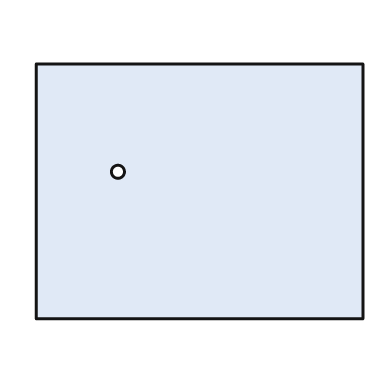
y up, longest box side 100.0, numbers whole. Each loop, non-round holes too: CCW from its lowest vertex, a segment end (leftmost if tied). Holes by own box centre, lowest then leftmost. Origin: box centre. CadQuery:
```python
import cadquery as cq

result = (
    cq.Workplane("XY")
    .moveTo(-50.0, -39.0)
    .lineTo(50.0, -39.0)
    .lineTo(50.0, 39.0)
    .lineTo(-50.0, 39.0)
    .close()
    .moveTo(-25.0, 6.0)
    .circle(2.0)
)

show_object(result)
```